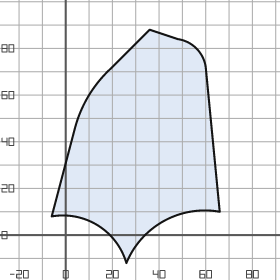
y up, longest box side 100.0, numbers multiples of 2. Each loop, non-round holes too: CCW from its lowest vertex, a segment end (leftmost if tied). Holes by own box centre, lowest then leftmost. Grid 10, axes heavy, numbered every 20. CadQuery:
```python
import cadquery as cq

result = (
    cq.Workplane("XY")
    .moveTo(26.0, -12.0)
    .threePointArc((42.0, 6.0), (66.0, 10.0))
    .lineTo(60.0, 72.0)
    .threePointArc((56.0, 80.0), (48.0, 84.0))
    .lineTo(36.0, 88.0)
    .lineTo(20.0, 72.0)
    .threePointArc((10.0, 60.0), (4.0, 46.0))
    .lineTo(-6.0, 8.0)
    .threePointArc((14.0, 4.0), (26.0, -12.0))
    .close()
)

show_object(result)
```